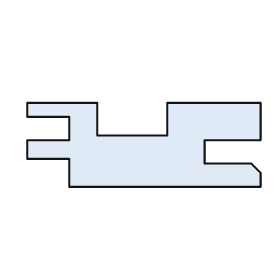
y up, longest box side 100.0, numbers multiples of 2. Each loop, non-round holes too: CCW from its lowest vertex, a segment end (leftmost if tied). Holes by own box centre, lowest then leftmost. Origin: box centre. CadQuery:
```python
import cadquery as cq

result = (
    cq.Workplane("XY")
    .moveTo(-32.0, -18.0)
    .lineTo(50.0, -18.0)
    .lineTo(50.0, -12.0)
    .lineTo(46.0, -8.0)
    .lineTo(26.0, -8.0)
    .lineTo(26.0, 2.0)
    .lineTo(50.0, 2.0)
    .lineTo(50.0, 18.0)
    .lineTo(10.0, 18.0)
    .lineTo(10.0, 4.0)
    .lineTo(-20.0, 4.0)
    .lineTo(-20.0, 18.0)
    .lineTo(-50.0, 18.0)
    .lineTo(-50.0, 12.0)
    .lineTo(-32.0, 12.0)
    .lineTo(-32.0, 2.0)
    .lineTo(-50.0, 2.0)
    .lineTo(-50.0, -6.0)
    .lineTo(-32.0, -6.0)
    .close()
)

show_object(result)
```